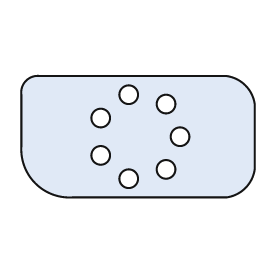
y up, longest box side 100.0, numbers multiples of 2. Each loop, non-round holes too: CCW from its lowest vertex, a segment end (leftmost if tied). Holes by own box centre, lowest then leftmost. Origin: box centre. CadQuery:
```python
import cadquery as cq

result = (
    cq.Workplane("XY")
    .moveTo(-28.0, -26.0)
    .lineTo(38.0, -26.0)
    .threePointArc((46.0, -22.0), (50.0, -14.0))
    .lineTo(50.0, 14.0)
    .threePointArc((46.0, 22.0), (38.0, 26.0))
    .lineTo(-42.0, 26.0)
    .threePointArc((-48.0, 24.0), (-50.0, 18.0))
    .lineTo(-50.0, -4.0)
    .threePointArc((-44.0, -20.0), (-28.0, -26.0))
    .close()
    .moveTo(-4.0, -18.0)
    .circle(4.0)
    .moveTo(12.0, -14.0)
    .circle(4.0)
    .moveTo(-16.0, -8.0)
    .circle(4.0)
    .moveTo(18.0, 0.0)
    .circle(4.0)
    .moveTo(-16.0, 8.0)
    .circle(4.0)
    .moveTo(12.0, 14.0)
    .circle(4.0)
    .moveTo(-4.0, 18.0)
    .circle(4.0)
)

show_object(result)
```